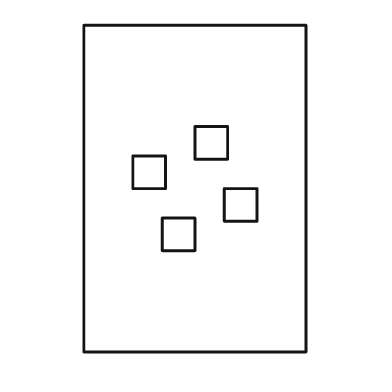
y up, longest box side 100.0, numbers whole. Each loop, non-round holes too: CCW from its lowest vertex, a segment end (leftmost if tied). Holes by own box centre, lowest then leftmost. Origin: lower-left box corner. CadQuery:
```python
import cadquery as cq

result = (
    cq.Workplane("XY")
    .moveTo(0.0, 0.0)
    .lineTo(68.0, 0.0)
    .lineTo(68.0, 100.0)
    .lineTo(0.0, 100.0)
    .close()
    .moveTo(24.0, 31.0)
    .lineTo(34.0, 31.0)
    .lineTo(34.0, 41.0)
    .lineTo(24.0, 41.0)
    .close()
    .moveTo(43.0, 40.0)
    .lineTo(53.0, 40.0)
    .lineTo(53.0, 50.0)
    .lineTo(43.0, 50.0)
    .close()
    .moveTo(15.0, 50.0)
    .lineTo(25.0, 50.0)
    .lineTo(25.0, 60.0)
    .lineTo(15.0, 60.0)
    .close()
    .moveTo(34.0, 59.0)
    .lineTo(44.0, 59.0)
    .lineTo(44.0, 69.0)
    .lineTo(34.0, 69.0)
    .close()
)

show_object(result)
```